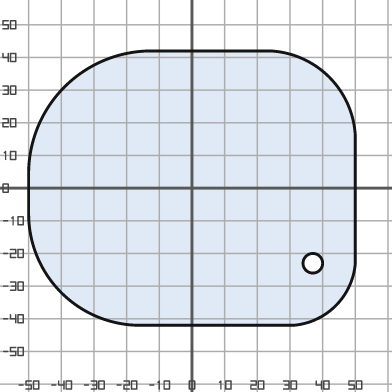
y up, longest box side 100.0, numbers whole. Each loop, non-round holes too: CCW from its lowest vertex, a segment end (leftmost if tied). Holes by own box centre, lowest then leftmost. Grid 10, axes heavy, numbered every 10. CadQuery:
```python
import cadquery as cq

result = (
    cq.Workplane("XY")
    .moveTo(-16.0, -42.0)
    .lineTo(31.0, -42.0)
    .threePointArc((44.0, -36.0), (50.0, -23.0))
    .lineTo(50.0, 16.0)
    .threePointArc((42.0, 34.0), (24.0, 42.0))
    .lineTo(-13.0, 42.0)
    .threePointArc((-39.0, 31.0), (-50.0, 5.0))
    .lineTo(-50.0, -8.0)
    .threePointArc((-40.0, -32.0), (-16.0, -42.0))
    .close()
    .moveTo(37.0, -23.0)
    .circle(3.0)
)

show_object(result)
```